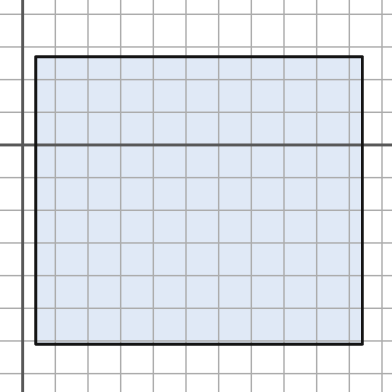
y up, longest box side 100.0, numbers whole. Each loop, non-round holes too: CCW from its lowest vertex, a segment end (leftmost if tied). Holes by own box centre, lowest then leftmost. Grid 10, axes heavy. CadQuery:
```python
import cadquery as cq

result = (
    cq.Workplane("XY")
    .moveTo(4.0, -61.0)
    .lineTo(104.0, -61.0)
    .lineTo(104.0, 27.0)
    .lineTo(4.0, 27.0)
    .close()
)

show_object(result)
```